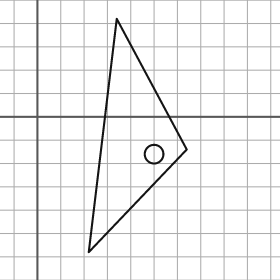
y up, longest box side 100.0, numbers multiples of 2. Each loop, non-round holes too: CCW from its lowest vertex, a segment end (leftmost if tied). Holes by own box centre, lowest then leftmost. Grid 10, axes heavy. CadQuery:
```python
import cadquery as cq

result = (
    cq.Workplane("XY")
    .moveTo(22.0, -58.0)
    .lineTo(64.0, -14.0)
    .lineTo(34.0, 42.0)
    .close()
    .moveTo(50.0, -16.0)
    .circle(4.0)
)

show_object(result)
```